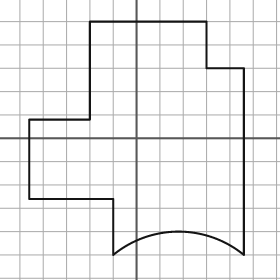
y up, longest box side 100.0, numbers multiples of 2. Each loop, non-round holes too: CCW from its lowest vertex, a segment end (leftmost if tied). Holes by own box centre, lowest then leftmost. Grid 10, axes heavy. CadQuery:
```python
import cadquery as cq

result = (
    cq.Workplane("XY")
    .moveTo(-10.0, -50.0)
    .threePointArc((18.0, -40.0), (46.0, -50.0))
    .lineTo(46.0, 30.0)
    .lineTo(30.0, 30.0)
    .lineTo(30.0, 50.0)
    .lineTo(-20.0, 50.0)
    .lineTo(-20.0, 8.0)
    .lineTo(-46.0, 8.0)
    .lineTo(-46.0, -26.0)
    .lineTo(-10.0, -26.0)
    .close()
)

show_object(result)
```